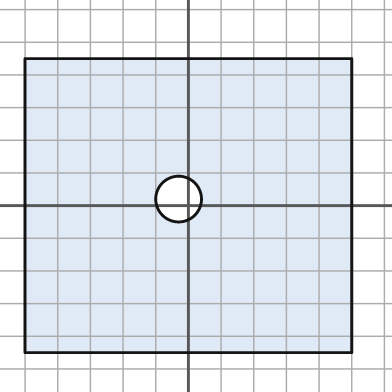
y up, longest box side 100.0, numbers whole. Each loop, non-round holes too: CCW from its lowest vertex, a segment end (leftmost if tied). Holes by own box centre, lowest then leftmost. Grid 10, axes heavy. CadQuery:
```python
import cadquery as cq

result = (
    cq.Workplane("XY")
    .moveTo(-50.0, -45.0)
    .lineTo(50.0, -45.0)
    .lineTo(50.0, 45.0)
    .lineTo(-50.0, 45.0)
    .close()
    .moveTo(-3.0, 2.0)
    .circle(7.0)
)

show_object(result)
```